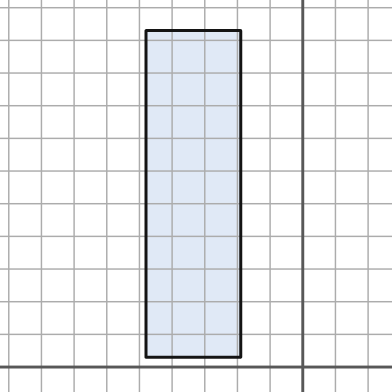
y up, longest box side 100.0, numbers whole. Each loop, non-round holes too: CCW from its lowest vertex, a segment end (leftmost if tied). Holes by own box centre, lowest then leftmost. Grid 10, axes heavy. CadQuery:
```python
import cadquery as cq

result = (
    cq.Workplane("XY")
    .moveTo(-48.0, 3.0)
    .lineTo(-19.0, 3.0)
    .lineTo(-19.0, 103.0)
    .lineTo(-48.0, 103.0)
    .close()
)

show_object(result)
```